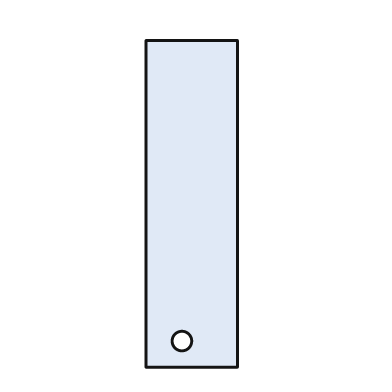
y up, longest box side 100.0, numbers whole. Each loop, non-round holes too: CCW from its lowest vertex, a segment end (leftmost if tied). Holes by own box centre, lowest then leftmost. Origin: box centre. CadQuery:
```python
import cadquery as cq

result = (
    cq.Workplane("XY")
    .moveTo(-14.0, -50.0)
    .lineTo(14.0, -50.0)
    .lineTo(14.0, 50.0)
    .lineTo(-14.0, 50.0)
    .close()
    .moveTo(-3.0, -42.0)
    .circle(3.0)
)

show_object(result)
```